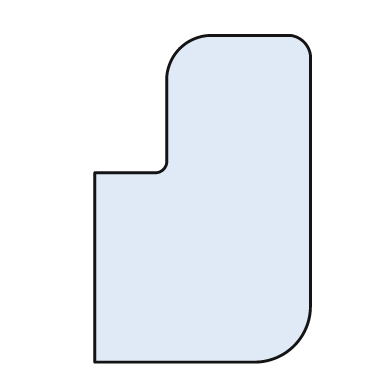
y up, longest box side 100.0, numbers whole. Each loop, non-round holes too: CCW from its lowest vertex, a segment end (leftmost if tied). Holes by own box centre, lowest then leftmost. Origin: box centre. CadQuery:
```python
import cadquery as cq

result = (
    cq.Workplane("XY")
    .moveTo(-33.0, -50.0)
    .lineTo(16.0, -50.0)
    .threePointArc((28.0, -45.0), (33.0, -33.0))
    .lineTo(33.0, 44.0)
    .threePointArc((31.0, 48.0), (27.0, 50.0))
    .lineTo(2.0, 50.0)
    .threePointArc((-7.0, 46.0), (-11.0, 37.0))
    .lineTo(-11.0, 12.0)
    .threePointArc((-12.0, 9.0), (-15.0, 8.0))
    .lineTo(-33.0, 8.0)
    .close()
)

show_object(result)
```